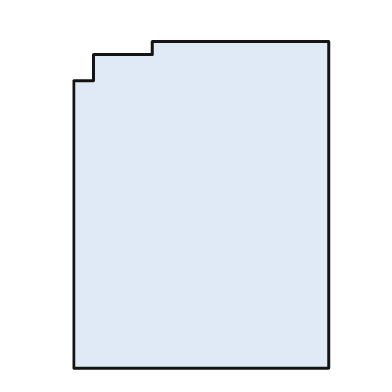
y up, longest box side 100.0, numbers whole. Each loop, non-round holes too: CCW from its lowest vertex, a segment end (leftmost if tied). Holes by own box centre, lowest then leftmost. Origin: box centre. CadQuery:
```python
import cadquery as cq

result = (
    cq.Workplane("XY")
    .moveTo(-39.0, -50.0)
    .lineTo(39.0, -50.0)
    .lineTo(39.0, 50.0)
    .lineTo(-15.0, 50.0)
    .lineTo(-15.0, 46.0)
    .lineTo(-33.0, 46.0)
    .lineTo(-33.0, 38.0)
    .lineTo(-39.0, 38.0)
    .close()
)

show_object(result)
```